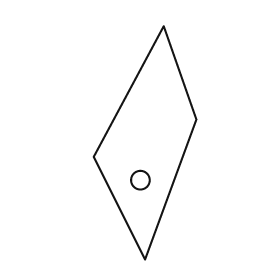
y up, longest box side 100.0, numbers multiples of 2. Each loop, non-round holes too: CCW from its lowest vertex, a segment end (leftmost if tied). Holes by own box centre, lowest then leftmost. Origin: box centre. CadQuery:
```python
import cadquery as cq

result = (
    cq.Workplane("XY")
    .moveTo(0.0, -50.0)
    .lineTo(22.0, 10.0)
    .lineTo(8.0, 50.0)
    .lineTo(-22.0, -6.0)
    .close()
    .moveTo(-2.0, -16.0)
    .circle(4.0)
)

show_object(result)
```